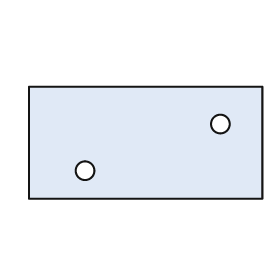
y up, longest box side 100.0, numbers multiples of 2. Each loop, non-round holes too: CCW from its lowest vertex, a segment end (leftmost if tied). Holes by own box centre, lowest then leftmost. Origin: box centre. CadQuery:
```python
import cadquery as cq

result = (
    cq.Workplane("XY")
    .moveTo(-50.0, -24.0)
    .lineTo(50.0, -24.0)
    .lineTo(50.0, 24.0)
    .lineTo(-50.0, 24.0)
    .close()
    .moveTo(-26.0, -12.0)
    .circle(4.0)
    .moveTo(32.0, 8.0)
    .circle(4.0)
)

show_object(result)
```